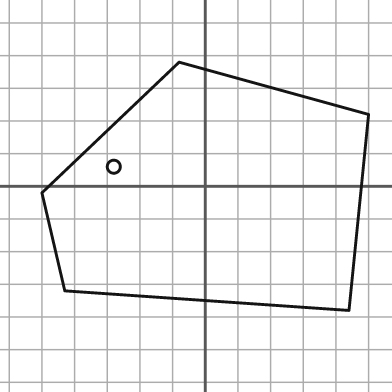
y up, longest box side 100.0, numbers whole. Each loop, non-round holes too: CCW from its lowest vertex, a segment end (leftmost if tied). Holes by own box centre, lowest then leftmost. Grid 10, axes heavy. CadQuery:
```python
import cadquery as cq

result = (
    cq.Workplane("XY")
    .moveTo(44.0, -38.0)
    .lineTo(50.0, 22.0)
    .lineTo(-8.0, 38.0)
    .lineTo(-50.0, -2.0)
    .lineTo(-43.0, -32.0)
    .close()
    .moveTo(-28.0, 6.0)
    .circle(2.0)
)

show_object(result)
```